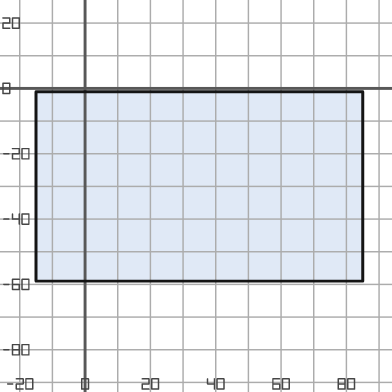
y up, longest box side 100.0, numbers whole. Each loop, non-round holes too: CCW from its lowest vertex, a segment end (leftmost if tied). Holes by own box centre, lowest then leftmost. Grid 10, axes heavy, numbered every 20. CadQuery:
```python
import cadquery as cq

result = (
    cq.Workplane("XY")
    .moveTo(-15.0, -59.0)
    .lineTo(85.0, -59.0)
    .lineTo(85.0, -1.0)
    .lineTo(-15.0, -1.0)
    .close()
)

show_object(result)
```